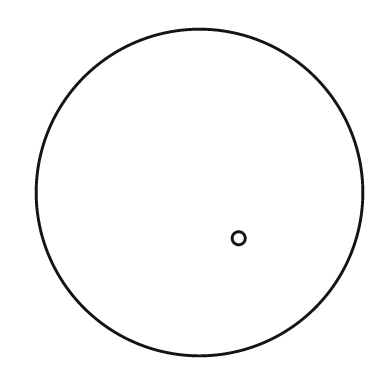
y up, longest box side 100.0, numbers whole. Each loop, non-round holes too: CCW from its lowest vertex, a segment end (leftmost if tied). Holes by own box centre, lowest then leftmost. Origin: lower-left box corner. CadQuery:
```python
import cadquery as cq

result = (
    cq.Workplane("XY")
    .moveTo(50.0, 50.0)
    .circle(50.0)
    .moveTo(62.0, 36.0)
    .circle(2.0)
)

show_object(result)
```